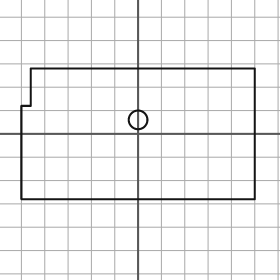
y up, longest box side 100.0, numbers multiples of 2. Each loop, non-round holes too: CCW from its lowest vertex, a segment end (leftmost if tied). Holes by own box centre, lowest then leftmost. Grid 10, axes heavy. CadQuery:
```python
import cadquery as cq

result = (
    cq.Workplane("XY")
    .moveTo(-50.0, -28.0)
    .lineTo(50.0, -28.0)
    .lineTo(50.0, 28.0)
    .lineTo(-46.0, 28.0)
    .lineTo(-46.0, 12.0)
    .lineTo(-50.0, 12.0)
    .close()
    .moveTo(0.0, 6.0)
    .circle(4.0)
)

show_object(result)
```